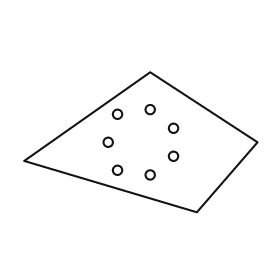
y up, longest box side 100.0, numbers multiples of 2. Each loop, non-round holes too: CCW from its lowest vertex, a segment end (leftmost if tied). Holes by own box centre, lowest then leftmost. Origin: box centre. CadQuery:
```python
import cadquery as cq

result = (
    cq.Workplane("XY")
    .moveTo(24.0, -30.0)
    .lineTo(50.0, 0.0)
    .lineTo(4.0, 30.0)
    .lineTo(-50.0, -8.0)
    .close()
    .moveTo(4.0, -14.0)
    .circle(2.0)
    .moveTo(-10.0, -12.0)
    .circle(2.0)
    .moveTo(14.0, -6.0)
    .circle(2.0)
    .moveTo(-14.0, 0.0)
    .circle(2.0)
    .moveTo(14.0, 6.0)
    .circle(2.0)
    .moveTo(-10.0, 12.0)
    .circle(2.0)
    .moveTo(4.0, 14.0)
    .circle(2.0)
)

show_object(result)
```